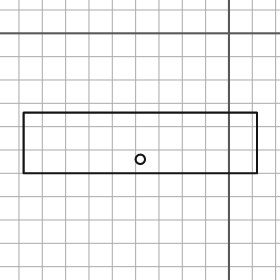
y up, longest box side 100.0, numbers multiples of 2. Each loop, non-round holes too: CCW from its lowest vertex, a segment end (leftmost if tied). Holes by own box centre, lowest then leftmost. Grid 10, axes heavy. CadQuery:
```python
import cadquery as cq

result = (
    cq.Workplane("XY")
    .moveTo(-88.0, -60.0)
    .lineTo(12.0, -60.0)
    .lineTo(12.0, -34.0)
    .lineTo(-88.0, -34.0)
    .close()
    .moveTo(-38.0, -54.0)
    .circle(2.0)
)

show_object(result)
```